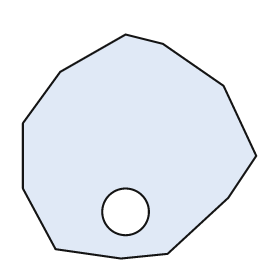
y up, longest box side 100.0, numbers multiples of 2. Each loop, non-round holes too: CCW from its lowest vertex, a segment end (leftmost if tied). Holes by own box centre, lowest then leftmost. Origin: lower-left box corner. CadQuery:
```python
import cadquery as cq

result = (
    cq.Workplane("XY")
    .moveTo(42.0, 0.0)
    .lineTo(62.0, 2.0)
    .lineTo(88.0, 26.0)
    .lineTo(100.0, 44.0)
    .lineTo(86.0, 74.0)
    .lineTo(60.0, 92.0)
    .lineTo(44.0, 96.0)
    .lineTo(16.0, 80.0)
    .lineTo(0.0, 58.0)
    .lineTo(0.0, 30.0)
    .lineTo(14.0, 4.0)
    .close()
    .moveTo(44.0, 20.0)
    .circle(10.0)
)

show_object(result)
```